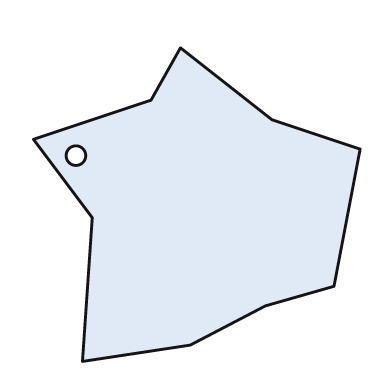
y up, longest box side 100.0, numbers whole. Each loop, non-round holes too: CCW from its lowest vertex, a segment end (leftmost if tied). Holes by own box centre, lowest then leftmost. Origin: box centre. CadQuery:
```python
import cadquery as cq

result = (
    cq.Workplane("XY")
    .moveTo(-35.0, -48.0)
    .lineTo(-2.0, -43.0)
    .lineTo(21.0, -31.0)
    .lineTo(42.0, -25.0)
    .lineTo(50.0, 17.0)
    .lineTo(23.0, 26.0)
    .lineTo(-5.0, 48.0)
    .lineTo(-14.0, 32.0)
    .lineTo(-50.0, 20.0)
    .lineTo(-32.0, -4.0)
    .close()
    .moveTo(-37.0, 15.0)
    .circle(3.0)
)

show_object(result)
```